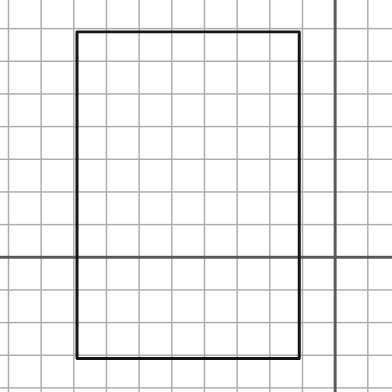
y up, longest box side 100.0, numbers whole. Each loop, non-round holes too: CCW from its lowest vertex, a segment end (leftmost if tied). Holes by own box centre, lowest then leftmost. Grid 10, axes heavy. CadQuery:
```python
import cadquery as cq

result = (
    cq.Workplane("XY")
    .moveTo(-79.0, -31.0)
    .lineTo(-11.0, -31.0)
    .lineTo(-11.0, 69.0)
    .lineTo(-79.0, 69.0)
    .close()
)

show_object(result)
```